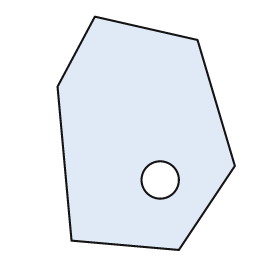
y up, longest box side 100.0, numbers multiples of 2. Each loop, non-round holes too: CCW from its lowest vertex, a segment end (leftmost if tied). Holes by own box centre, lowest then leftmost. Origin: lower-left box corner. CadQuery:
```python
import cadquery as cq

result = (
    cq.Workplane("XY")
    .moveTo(52.0, 0.0)
    .lineTo(76.0, 36.0)
    .lineTo(60.0, 90.0)
    .lineTo(16.0, 100.0)
    .lineTo(0.0, 70.0)
    .lineTo(6.0, 4.0)
    .close()
    .moveTo(44.0, 30.0)
    .circle(8.0)
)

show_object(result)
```